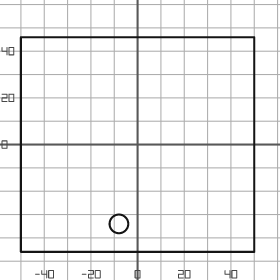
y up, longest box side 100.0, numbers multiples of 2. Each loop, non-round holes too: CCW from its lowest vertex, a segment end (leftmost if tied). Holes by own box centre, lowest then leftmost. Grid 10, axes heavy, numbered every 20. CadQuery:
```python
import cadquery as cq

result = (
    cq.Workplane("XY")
    .moveTo(-50.0, -46.0)
    .lineTo(50.0, -46.0)
    .lineTo(50.0, 46.0)
    .lineTo(-50.0, 46.0)
    .close()
    .moveTo(-8.0, -34.0)
    .circle(4.0)
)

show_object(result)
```